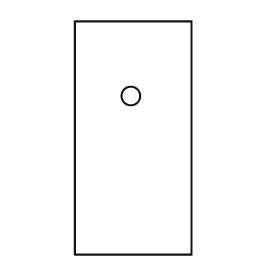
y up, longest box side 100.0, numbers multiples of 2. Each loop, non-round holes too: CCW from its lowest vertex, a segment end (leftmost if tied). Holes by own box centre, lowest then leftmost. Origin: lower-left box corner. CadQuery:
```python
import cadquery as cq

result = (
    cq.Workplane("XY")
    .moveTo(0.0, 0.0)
    .lineTo(50.0, 0.0)
    .lineTo(50.0, 100.0)
    .lineTo(0.0, 100.0)
    .close()
    .moveTo(24.0, 68.0)
    .circle(4.0)
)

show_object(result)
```